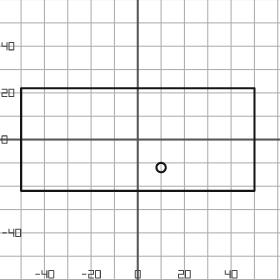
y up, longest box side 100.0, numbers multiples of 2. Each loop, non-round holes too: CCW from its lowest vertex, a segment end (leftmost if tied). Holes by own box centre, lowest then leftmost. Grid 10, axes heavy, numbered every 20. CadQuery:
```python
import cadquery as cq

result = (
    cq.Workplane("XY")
    .moveTo(-50.0, -22.0)
    .lineTo(50.0, -22.0)
    .lineTo(50.0, 22.0)
    .lineTo(-50.0, 22.0)
    .close()
    .moveTo(10.0, -12.0)
    .circle(2.0)
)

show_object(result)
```